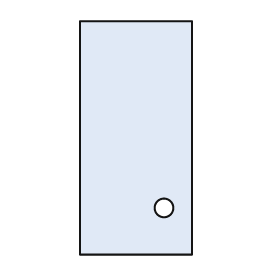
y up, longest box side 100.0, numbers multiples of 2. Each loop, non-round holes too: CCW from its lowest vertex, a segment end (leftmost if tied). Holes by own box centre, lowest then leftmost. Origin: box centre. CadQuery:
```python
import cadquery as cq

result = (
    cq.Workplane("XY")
    .moveTo(-24.0, -50.0)
    .lineTo(24.0, -50.0)
    .lineTo(24.0, 50.0)
    .lineTo(-24.0, 50.0)
    .close()
    .moveTo(12.0, -30.0)
    .circle(4.0)
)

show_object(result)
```